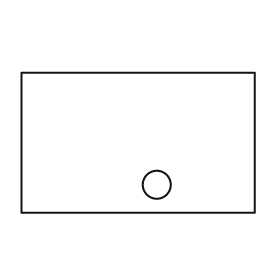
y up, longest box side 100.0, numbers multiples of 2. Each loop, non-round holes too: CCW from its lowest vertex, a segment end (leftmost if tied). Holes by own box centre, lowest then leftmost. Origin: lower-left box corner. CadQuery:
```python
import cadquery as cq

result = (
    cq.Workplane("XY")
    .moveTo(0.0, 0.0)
    .lineTo(100.0, 0.0)
    .lineTo(100.0, 60.0)
    .lineTo(0.0, 60.0)
    .close()
    .moveTo(58.0, 12.0)
    .circle(6.0)
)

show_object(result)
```